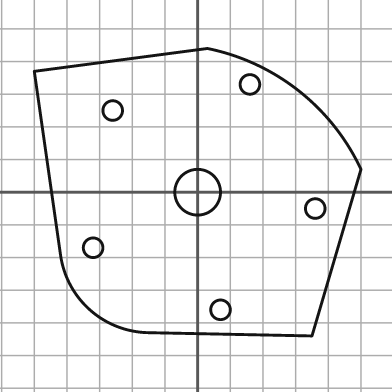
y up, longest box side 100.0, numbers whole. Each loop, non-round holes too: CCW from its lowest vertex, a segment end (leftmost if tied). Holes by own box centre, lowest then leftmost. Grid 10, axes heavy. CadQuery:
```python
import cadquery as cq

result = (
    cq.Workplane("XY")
    .moveTo(35.0, -44.0)
    .lineTo(50.0, 7.0)
    .threePointArc((31.0, 31.0), (3.0, 44.0))
    .lineTo(-50.0, 37.0)
    .lineTo(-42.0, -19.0)
    .threePointArc((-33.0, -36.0), (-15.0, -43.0))
    .close()
    .moveTo(7.0, -36.0)
    .circle(3.0)
    .moveTo(-32.0, -17.0)
    .circle(3.0)
    .moveTo(36.0, -5.0)
    .circle(3.0)
    .moveTo(0.0, 0.0)
    .circle(7.0)
    .moveTo(-26.0, 25.0)
    .circle(3.0)
    .moveTo(16.0, 33.0)
    .circle(3.0)
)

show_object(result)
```